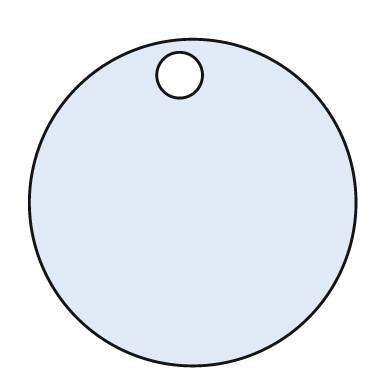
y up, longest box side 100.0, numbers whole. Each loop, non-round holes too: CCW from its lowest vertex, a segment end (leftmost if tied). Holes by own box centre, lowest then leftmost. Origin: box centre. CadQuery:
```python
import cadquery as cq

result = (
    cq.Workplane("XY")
    .moveTo(0.0, 0.0)
    .circle(50.0)
    .moveTo(-4.0, 39.0)
    .circle(7.0)
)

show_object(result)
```